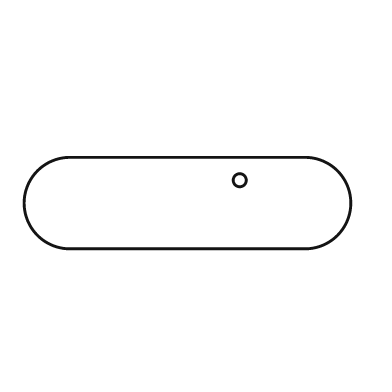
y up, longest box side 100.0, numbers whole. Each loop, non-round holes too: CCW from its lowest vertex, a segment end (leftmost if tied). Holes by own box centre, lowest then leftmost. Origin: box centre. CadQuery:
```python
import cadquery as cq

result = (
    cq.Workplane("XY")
    .moveTo(-36.0, -14.0)
    .lineTo(36.0, -14.0)
    .threePointArc((50.0, 0.0), (36.0, 14.0))
    .lineTo(-36.0, 14.0)
    .threePointArc((-50.0, 0.0), (-36.0, -14.0))
    .close()
    .moveTo(16.0, 7.0)
    .circle(2.0)
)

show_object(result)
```